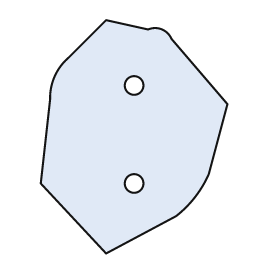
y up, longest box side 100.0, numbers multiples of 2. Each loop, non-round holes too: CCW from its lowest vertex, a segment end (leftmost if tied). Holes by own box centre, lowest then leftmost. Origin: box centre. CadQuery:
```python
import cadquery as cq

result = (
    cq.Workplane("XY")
    .moveTo(-12.0, -50.0)
    .lineTo(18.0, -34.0)
    .threePointArc((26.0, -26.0), (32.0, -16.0))
    .lineTo(40.0, 14.0)
    .lineTo(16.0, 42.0)
    .threePointArc((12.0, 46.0), (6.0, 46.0))
    .lineTo(-12.0, 50.0)
    .lineTo(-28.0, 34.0)
    .threePointArc((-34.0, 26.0), (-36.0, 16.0))
    .lineTo(-40.0, -20.0)
    .close()
    .moveTo(0.0, -20.0)
    .circle(4.0)
    .moveTo(0.0, 22.0)
    .circle(4.0)
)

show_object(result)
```